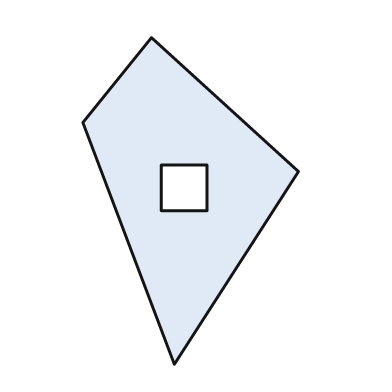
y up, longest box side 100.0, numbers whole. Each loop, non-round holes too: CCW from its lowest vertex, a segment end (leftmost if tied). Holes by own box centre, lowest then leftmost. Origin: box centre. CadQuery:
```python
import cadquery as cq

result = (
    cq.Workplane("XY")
    .moveTo(-5.0, -50.0)
    .lineTo(33.0, 9.0)
    .lineTo(-12.0, 50.0)
    .lineTo(-33.0, 24.0)
    .close()
    .moveTo(-9.0, -3.0)
    .lineTo(5.0, -3.0)
    .lineTo(5.0, 11.0)
    .lineTo(-9.0, 11.0)
    .close()
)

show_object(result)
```